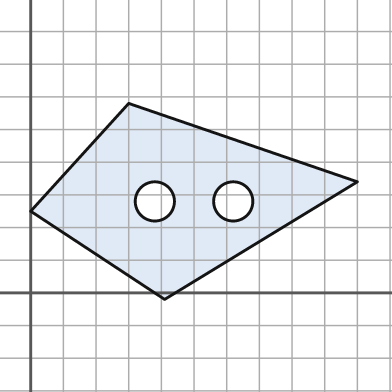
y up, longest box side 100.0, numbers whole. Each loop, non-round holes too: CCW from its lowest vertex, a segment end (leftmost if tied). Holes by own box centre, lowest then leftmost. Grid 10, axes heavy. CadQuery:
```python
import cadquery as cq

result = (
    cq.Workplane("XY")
    .moveTo(41.0, -2.0)
    .lineTo(100.0, 34.0)
    .lineTo(30.0, 58.0)
    .lineTo(0.0, 25.0)
    .close()
    .moveTo(38.0, 28.0)
    .circle(6.0)
    .moveTo(62.0, 28.0)
    .circle(6.0)
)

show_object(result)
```